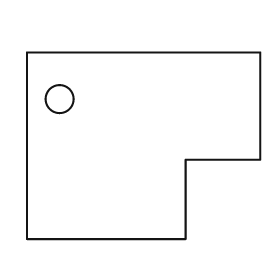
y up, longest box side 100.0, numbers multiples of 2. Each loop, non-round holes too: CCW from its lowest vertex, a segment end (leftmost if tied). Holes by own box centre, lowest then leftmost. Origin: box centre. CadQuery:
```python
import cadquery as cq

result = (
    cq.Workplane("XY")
    .moveTo(-50.0, -40.0)
    .lineTo(18.0, -40.0)
    .lineTo(18.0, -6.0)
    .lineTo(50.0, -6.0)
    .lineTo(50.0, 40.0)
    .lineTo(-50.0, 40.0)
    .close()
    .moveTo(-36.0, 20.0)
    .circle(6.0)
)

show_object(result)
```